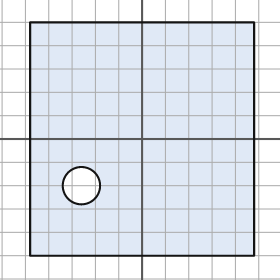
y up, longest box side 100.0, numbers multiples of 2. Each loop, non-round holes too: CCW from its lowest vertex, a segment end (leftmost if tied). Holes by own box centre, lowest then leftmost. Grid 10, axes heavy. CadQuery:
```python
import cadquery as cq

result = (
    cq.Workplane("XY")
    .moveTo(-48.0, -50.0)
    .lineTo(48.0, -50.0)
    .lineTo(48.0, 50.0)
    .lineTo(-48.0, 50.0)
    .close()
    .moveTo(-26.0, -20.0)
    .circle(8.0)
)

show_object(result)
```